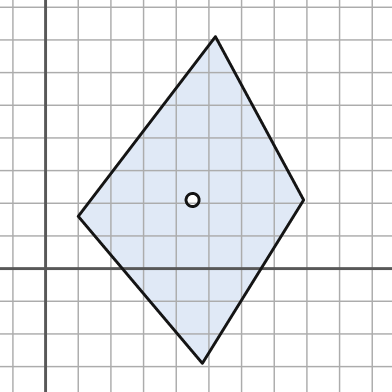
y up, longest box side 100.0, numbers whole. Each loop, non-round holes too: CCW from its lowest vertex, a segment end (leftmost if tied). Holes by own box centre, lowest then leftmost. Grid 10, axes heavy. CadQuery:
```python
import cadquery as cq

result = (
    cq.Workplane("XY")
    .moveTo(48.0, -29.0)
    .lineTo(79.0, 21.0)
    .lineTo(52.0, 71.0)
    .lineTo(10.0, 16.0)
    .close()
    .moveTo(45.0, 21.0)
    .circle(2.0)
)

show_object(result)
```